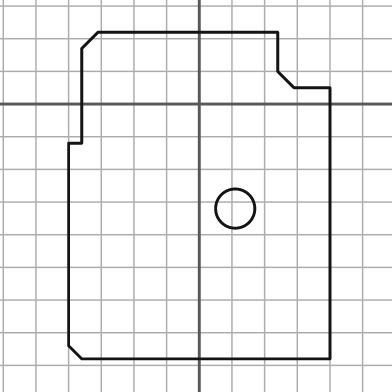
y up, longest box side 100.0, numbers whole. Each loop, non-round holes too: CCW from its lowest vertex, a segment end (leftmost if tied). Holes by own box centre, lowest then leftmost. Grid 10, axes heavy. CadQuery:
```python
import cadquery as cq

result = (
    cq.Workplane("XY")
    .moveTo(-36.0, -78.0)
    .lineTo(40.0, -78.0)
    .lineTo(40.0, 5.0)
    .lineTo(29.0, 5.0)
    .lineTo(24.0, 10.0)
    .lineTo(24.0, 22.0)
    .lineTo(-31.0, 22.0)
    .lineTo(-36.0, 17.0)
    .lineTo(-36.0, -12.0)
    .lineTo(-40.0, -12.0)
    .lineTo(-40.0, -74.0)
    .close()
    .moveTo(11.0, -32.0)
    .circle(6.0)
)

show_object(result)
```